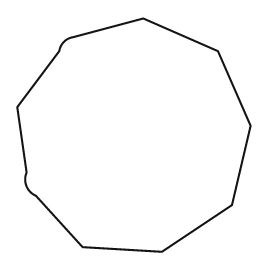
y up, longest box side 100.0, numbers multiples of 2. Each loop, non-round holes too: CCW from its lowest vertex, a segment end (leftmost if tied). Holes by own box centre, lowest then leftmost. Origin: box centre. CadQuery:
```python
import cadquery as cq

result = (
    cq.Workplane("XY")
    .moveTo(12.0, -50.0)
    .lineTo(42.0, -30.0)
    .lineTo(50.0, 4.0)
    .lineTo(36.0, 36.0)
    .lineTo(4.0, 50.0)
    .lineTo(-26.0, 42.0)
    .threePointArc((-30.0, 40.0), (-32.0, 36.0))
    .lineTo(-50.0, 12.0)
    .lineTo(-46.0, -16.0)
    .threePointArc((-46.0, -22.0), (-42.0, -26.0))
    .lineTo(-22.0, -48.0)
    .close()
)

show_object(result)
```